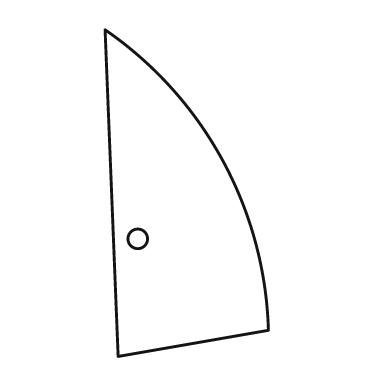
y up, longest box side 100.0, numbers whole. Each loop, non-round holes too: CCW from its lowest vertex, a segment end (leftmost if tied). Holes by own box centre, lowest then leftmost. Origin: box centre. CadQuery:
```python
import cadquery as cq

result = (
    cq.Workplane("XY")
    .moveTo(-21.0, -50.0)
    .lineTo(25.0, -42.0)
    .threePointArc((11.0, 10.0), (-25.0, 50.0))
    .close()
    .moveTo(-15.0, -14.0)
    .circle(3.0)
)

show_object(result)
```